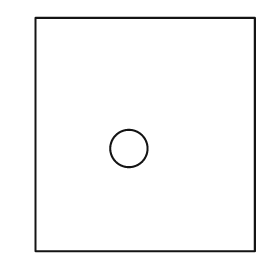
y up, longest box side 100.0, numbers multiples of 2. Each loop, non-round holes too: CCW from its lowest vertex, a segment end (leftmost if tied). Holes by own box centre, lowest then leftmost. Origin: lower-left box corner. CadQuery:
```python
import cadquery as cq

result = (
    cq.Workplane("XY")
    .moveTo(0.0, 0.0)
    .lineTo(94.0, 0.0)
    .lineTo(94.0, 100.0)
    .lineTo(0.0, 100.0)
    .close()
    .moveTo(40.0, 44.0)
    .circle(8.0)
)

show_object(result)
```